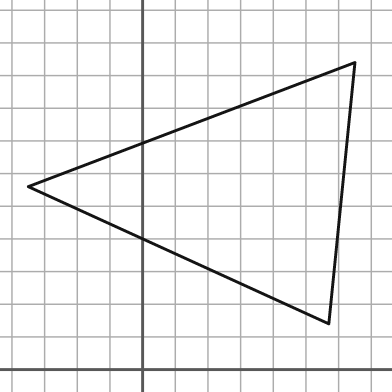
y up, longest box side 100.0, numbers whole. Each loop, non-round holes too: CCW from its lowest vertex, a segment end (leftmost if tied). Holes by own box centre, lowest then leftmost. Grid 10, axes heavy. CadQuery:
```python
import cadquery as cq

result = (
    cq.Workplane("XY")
    .moveTo(57.0, 14.0)
    .lineTo(65.0, 94.0)
    .lineTo(-35.0, 56.0)
    .close()
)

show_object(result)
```